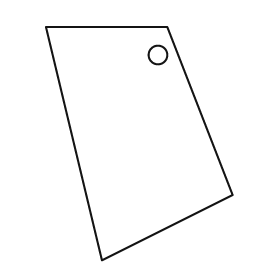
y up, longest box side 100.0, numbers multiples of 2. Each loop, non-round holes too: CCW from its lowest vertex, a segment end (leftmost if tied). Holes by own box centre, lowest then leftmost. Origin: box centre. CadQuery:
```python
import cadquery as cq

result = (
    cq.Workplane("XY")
    .moveTo(-16.0, -50.0)
    .lineTo(40.0, -22.0)
    .lineTo(12.0, 50.0)
    .lineTo(-40.0, 50.0)
    .close()
    .moveTo(8.0, 38.0)
    .circle(4.0)
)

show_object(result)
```